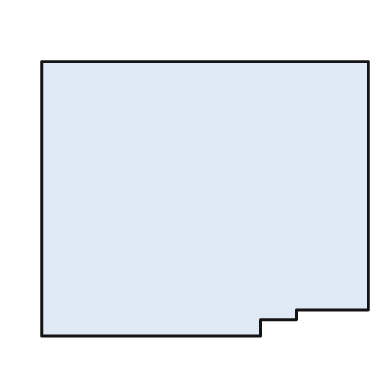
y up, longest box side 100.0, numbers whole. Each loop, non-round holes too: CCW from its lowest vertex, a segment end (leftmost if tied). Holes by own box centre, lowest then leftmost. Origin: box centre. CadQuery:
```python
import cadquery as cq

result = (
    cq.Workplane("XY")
    .moveTo(-50.0, -42.0)
    .lineTo(17.0, -42.0)
    .lineTo(17.0, -37.0)
    .lineTo(28.0, -37.0)
    .lineTo(28.0, -34.0)
    .lineTo(50.0, -34.0)
    .lineTo(50.0, 42.0)
    .lineTo(-50.0, 42.0)
    .close()
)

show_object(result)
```